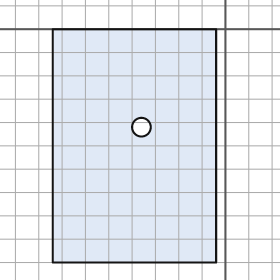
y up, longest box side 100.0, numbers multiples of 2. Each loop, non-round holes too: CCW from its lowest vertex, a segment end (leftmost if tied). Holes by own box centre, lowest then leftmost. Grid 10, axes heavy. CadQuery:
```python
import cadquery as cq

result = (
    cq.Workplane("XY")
    .moveTo(-74.0, -100.0)
    .lineTo(-4.0, -100.0)
    .lineTo(-4.0, 0.0)
    .lineTo(-74.0, 0.0)
    .close()
    .moveTo(-36.0, -42.0)
    .circle(4.0)
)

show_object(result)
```